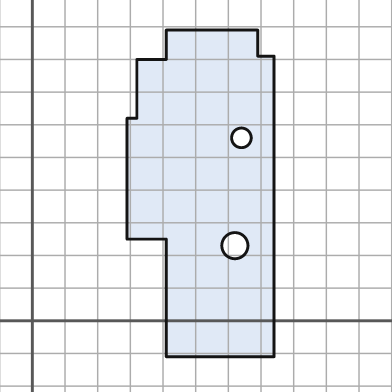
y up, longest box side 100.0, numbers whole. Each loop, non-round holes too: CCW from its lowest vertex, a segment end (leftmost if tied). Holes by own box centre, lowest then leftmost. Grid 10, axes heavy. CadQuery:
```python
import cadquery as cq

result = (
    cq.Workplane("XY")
    .moveTo(41.0, -11.0)
    .lineTo(74.0, -11.0)
    .lineTo(74.0, 81.0)
    .lineTo(69.0, 81.0)
    .lineTo(69.0, 89.0)
    .lineTo(41.0, 89.0)
    .lineTo(41.0, 80.0)
    .lineTo(32.0, 80.0)
    .lineTo(32.0, 62.0)
    .lineTo(29.0, 62.0)
    .lineTo(29.0, 25.0)
    .lineTo(41.0, 25.0)
    .close()
    .moveTo(62.0, 23.0)
    .circle(4.0)
    .moveTo(64.0, 56.0)
    .circle(3.0)
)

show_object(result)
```